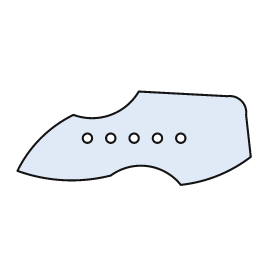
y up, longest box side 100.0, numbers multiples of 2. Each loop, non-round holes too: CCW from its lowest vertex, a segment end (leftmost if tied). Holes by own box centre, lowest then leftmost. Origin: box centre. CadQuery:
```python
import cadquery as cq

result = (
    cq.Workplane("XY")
    .moveTo(20.0, -20.0)
    .threePointArc((36.0, -16.0), (50.0, -8.0))
    .lineTo(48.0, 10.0)
    .threePointArc((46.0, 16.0), (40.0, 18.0))
    .lineTo(2.0, 20.0)
    .threePointArc((-10.0, 10.0), (-26.0, 10.0))
    .threePointArc((-40.0, 0.0), (-50.0, -14.0))
    .threePointArc((-30.0, -18.0), (-10.0, -16.0))
    .threePointArc((6.0, -12.0), (20.0, -20.0))
    .close()
    .moveTo(-20.0, 0.0)
    .circle(2.0)
    .moveTo(-10.0, 0.0)
    .circle(2.0)
    .moveTo(0.0, 0.0)
    .circle(2.0)
    .moveTo(10.0, 0.0)
    .circle(2.0)
    .moveTo(20.0, 0.0)
    .circle(2.0)
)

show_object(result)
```